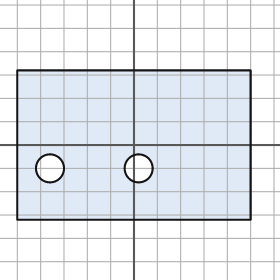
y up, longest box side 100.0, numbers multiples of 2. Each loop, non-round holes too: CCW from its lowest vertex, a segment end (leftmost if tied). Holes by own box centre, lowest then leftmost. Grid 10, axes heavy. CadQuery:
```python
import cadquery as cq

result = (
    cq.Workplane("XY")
    .moveTo(-50.0, -32.0)
    .lineTo(50.0, -32.0)
    .lineTo(50.0, 32.0)
    .lineTo(-50.0, 32.0)
    .close()
    .moveTo(-36.0, -10.0)
    .circle(6.0)
    .moveTo(2.0, -10.0)
    .circle(6.0)
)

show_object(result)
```